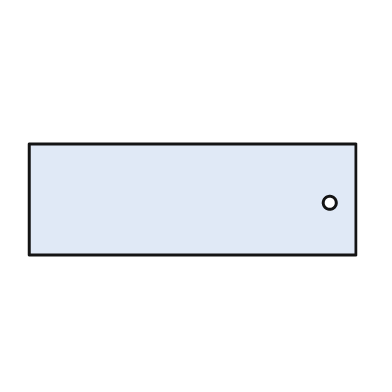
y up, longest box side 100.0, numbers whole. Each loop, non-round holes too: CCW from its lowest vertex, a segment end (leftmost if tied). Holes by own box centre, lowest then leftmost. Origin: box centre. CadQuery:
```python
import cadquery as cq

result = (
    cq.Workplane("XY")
    .moveTo(-50.0, -17.0)
    .lineTo(50.0, -17.0)
    .lineTo(50.0, 17.0)
    .lineTo(-50.0, 17.0)
    .close()
    .moveTo(42.0, -1.0)
    .circle(2.0)
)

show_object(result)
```